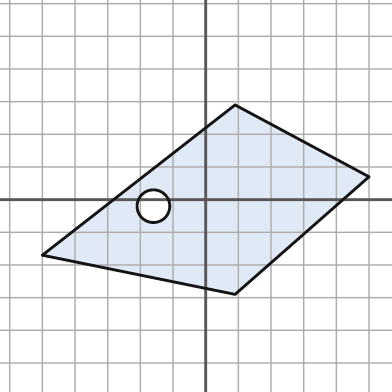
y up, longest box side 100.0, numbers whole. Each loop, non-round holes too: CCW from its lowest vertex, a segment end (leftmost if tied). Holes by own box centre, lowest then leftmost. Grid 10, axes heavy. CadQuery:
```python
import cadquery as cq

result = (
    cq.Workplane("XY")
    .moveTo(9.0, -29.0)
    .lineTo(50.0, 7.0)
    .lineTo(9.0, 29.0)
    .lineTo(-50.0, -17.0)
    .close()
    .moveTo(-16.0, -2.0)
    .circle(5.0)
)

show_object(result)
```